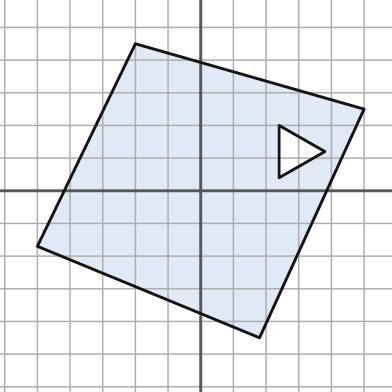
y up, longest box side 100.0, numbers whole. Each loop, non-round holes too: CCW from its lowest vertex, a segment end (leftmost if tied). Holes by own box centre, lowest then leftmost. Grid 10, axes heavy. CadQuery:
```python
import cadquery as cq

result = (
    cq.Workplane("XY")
    .moveTo(18.0, -45.0)
    .lineTo(50.0, 25.0)
    .lineTo(-20.0, 45.0)
    .lineTo(-50.0, -17.0)
    .close()
    .moveTo(24.0, 4.0)
    .lineTo(38.0, 12.0)
    .lineTo(24.0, 20.0)
    .close()
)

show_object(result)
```